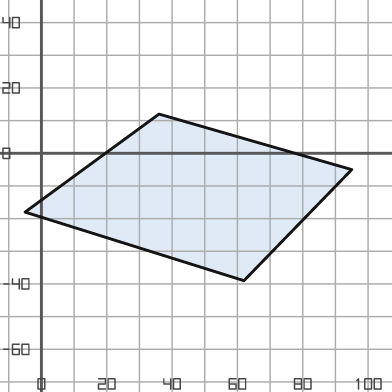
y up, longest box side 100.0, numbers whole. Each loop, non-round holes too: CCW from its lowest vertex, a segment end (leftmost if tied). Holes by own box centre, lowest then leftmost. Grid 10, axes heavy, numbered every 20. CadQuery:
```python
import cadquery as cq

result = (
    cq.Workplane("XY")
    .moveTo(62.0, -39.0)
    .lineTo(95.0, -5.0)
    .lineTo(36.0, 12.0)
    .lineTo(-5.0, -18.0)
    .close()
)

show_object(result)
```